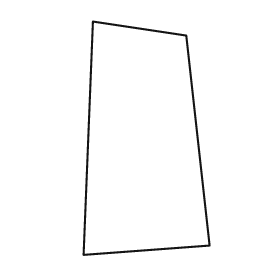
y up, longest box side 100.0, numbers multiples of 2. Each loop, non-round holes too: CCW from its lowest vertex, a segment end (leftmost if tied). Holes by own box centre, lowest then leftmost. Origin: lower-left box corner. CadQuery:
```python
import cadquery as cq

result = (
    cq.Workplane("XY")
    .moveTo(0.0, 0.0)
    .lineTo(54.0, 4.0)
    .lineTo(44.0, 94.0)
    .lineTo(4.0, 100.0)
    .close()
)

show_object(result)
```